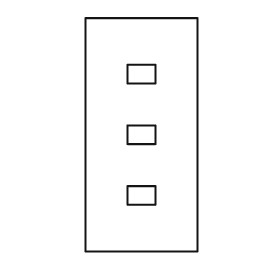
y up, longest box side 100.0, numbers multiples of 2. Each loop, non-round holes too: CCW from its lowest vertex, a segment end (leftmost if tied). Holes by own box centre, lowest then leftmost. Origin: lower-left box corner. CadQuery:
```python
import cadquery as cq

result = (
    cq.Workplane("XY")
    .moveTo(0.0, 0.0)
    .lineTo(48.0, 0.0)
    .lineTo(48.0, 100.0)
    .lineTo(0.0, 100.0)
    .close()
    .moveTo(18.0, 20.0)
    .lineTo(30.0, 20.0)
    .lineTo(30.0, 28.0)
    .lineTo(18.0, 28.0)
    .close()
    .moveTo(18.0, 46.0)
    .lineTo(30.0, 46.0)
    .lineTo(30.0, 54.0)
    .lineTo(18.0, 54.0)
    .close()
    .moveTo(18.0, 72.0)
    .lineTo(30.0, 72.0)
    .lineTo(30.0, 80.0)
    .lineTo(18.0, 80.0)
    .close()
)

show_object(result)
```